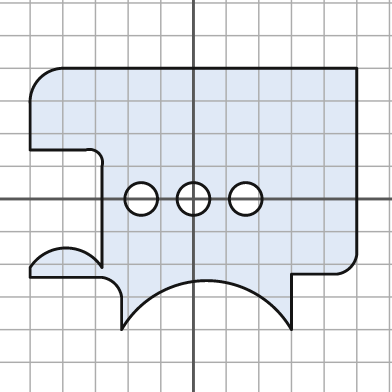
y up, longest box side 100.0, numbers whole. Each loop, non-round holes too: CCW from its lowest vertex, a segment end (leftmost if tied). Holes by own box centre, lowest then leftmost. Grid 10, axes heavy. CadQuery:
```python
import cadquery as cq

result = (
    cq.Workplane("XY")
    .moveTo(-22.0, -40.0)
    .threePointArc((4.0, -25.0), (30.0, -40.0))
    .lineTo(30.0, -23.0)
    .lineTo(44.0, -23.0)
    .threePointArc((48.0, -21.0), (50.0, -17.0))
    .lineTo(50.0, 40.0)
    .lineTo(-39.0, 40.0)
    .threePointArc((-47.0, 37.0), (-50.0, 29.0))
    .lineTo(-50.0, 15.0)
    .lineTo(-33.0, 15.0)
    .threePointArc((-29.0, 14.0), (-28.0, 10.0))
    .lineTo(-28.0, -21.0)
    .threePointArc((-39.0, -15.0), (-50.0, -21.0))
    .lineTo(-50.0, -24.0)
    .lineTo(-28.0, -24.0)
    .threePointArc((-24.0, -26.0), (-22.0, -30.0))
    .close()
    .moveTo(-16.0, 0.0)
    .circle(5.0)
    .moveTo(0.0, 0.0)
    .circle(5.0)
    .moveTo(16.0, 0.0)
    .circle(5.0)
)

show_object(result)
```